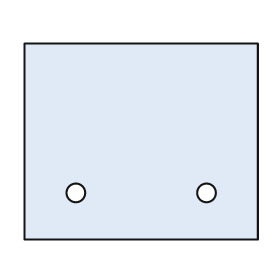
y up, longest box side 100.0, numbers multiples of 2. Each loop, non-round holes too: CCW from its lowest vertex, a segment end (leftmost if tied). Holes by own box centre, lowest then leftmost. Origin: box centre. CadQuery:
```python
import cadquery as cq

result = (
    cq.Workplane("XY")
    .moveTo(-50.0, -42.0)
    .lineTo(50.0, -42.0)
    .lineTo(50.0, 42.0)
    .lineTo(-50.0, 42.0)
    .close()
    .moveTo(-28.0, -22.0)
    .circle(4.0)
    .moveTo(28.0, -22.0)
    .circle(4.0)
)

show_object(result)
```